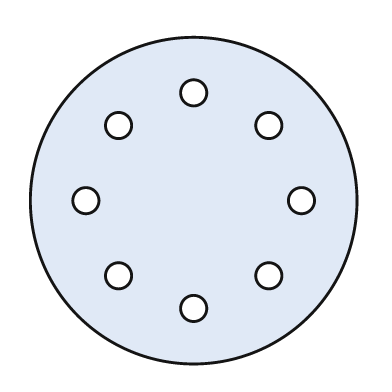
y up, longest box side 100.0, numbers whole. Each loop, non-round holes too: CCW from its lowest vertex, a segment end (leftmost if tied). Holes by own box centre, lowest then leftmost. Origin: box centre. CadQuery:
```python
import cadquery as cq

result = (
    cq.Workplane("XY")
    .moveTo(0.0, 0.0)
    .circle(50.0)
    .moveTo(0.0, -33.0)
    .circle(4.0)
    .moveTo(-23.0, -23.0)
    .circle(4.0)
    .moveTo(23.0, -23.0)
    .circle(4.0)
    .moveTo(-33.0, 0.0)
    .circle(4.0)
    .moveTo(33.0, 0.0)
    .circle(4.0)
    .moveTo(-23.0, 23.0)
    .circle(4.0)
    .moveTo(23.0, 23.0)
    .circle(4.0)
    .moveTo(0.0, 33.0)
    .circle(4.0)
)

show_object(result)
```